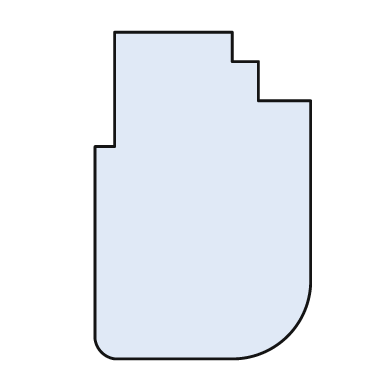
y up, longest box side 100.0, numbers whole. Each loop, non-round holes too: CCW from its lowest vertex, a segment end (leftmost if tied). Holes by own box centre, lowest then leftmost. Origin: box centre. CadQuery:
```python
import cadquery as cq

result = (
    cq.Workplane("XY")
    .moveTo(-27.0, -50.0)
    .lineTo(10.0, -50.0)
    .threePointArc((26.0, -43.0), (33.0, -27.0))
    .lineTo(33.0, 29.0)
    .lineTo(17.0, 29.0)
    .lineTo(17.0, 41.0)
    .lineTo(9.0, 41.0)
    .lineTo(9.0, 50.0)
    .lineTo(-27.0, 50.0)
    .lineTo(-27.0, 15.0)
    .lineTo(-33.0, 15.0)
    .lineTo(-33.0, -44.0)
    .threePointArc((-31.0, -48.0), (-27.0, -50.0))
    .close()
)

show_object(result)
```